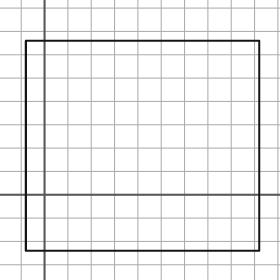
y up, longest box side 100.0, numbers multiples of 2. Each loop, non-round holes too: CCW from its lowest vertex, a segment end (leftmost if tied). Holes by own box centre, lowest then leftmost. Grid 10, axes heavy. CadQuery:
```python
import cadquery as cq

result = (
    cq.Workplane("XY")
    .moveTo(-8.0, -24.0)
    .lineTo(92.0, -24.0)
    .lineTo(92.0, 66.0)
    .lineTo(-8.0, 66.0)
    .close()
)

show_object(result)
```